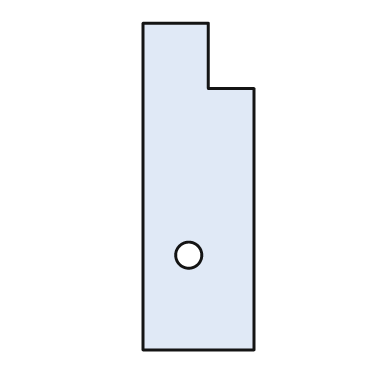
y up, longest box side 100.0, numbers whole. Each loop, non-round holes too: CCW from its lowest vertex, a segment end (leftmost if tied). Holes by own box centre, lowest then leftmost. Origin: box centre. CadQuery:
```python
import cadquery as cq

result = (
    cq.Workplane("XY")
    .moveTo(-17.0, -50.0)
    .lineTo(17.0, -50.0)
    .lineTo(17.0, 30.0)
    .lineTo(3.0, 30.0)
    .lineTo(3.0, 50.0)
    .lineTo(-17.0, 50.0)
    .close()
    .moveTo(-3.0, -21.0)
    .circle(4.0)
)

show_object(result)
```